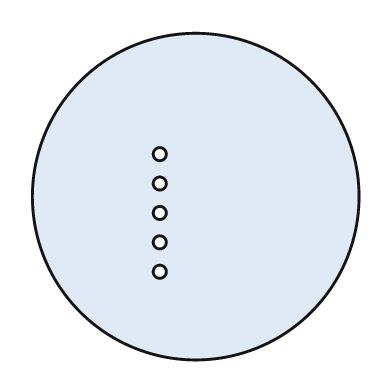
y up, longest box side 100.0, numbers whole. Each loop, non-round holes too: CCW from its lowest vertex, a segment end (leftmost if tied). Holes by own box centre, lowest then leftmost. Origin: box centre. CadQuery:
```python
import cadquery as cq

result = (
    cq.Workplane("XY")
    .moveTo(0.0, 0.0)
    .circle(50.0)
    .moveTo(-11.0, -23.0)
    .circle(2.0)
    .moveTo(-11.0, -14.0)
    .circle(2.0)
    .moveTo(-11.0, -5.0)
    .circle(2.0)
    .moveTo(-11.0, 4.0)
    .circle(2.0)
    .moveTo(-11.0, 13.0)
    .circle(2.0)
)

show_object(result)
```